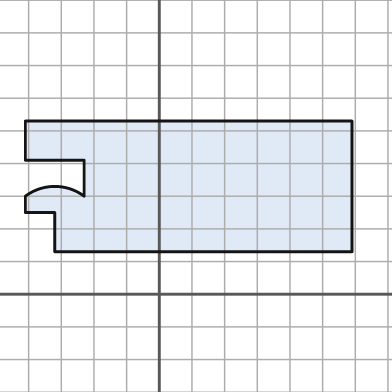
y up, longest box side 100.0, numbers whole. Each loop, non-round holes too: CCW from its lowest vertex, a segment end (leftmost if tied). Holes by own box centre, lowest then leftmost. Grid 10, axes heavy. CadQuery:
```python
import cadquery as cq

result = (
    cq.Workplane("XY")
    .moveTo(-32.0, 13.0)
    .lineTo(59.0, 13.0)
    .lineTo(59.0, 53.0)
    .lineTo(-41.0, 53.0)
    .lineTo(-41.0, 41.0)
    .lineTo(-23.0, 41.0)
    .lineTo(-23.0, 30.0)
    .threePointArc((-32.0, 33.0), (-41.0, 30.0))
    .lineTo(-41.0, 25.0)
    .lineTo(-32.0, 25.0)
    .close()
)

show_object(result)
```